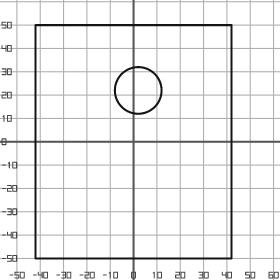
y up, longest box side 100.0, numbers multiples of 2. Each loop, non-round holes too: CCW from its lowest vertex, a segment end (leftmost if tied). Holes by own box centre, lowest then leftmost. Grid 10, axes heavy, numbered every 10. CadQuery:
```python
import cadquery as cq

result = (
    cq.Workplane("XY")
    .moveTo(-42.0, -50.0)
    .lineTo(42.0, -50.0)
    .lineTo(42.0, 50.0)
    .lineTo(-42.0, 50.0)
    .close()
    .moveTo(2.0, 22.0)
    .circle(10.0)
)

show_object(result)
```